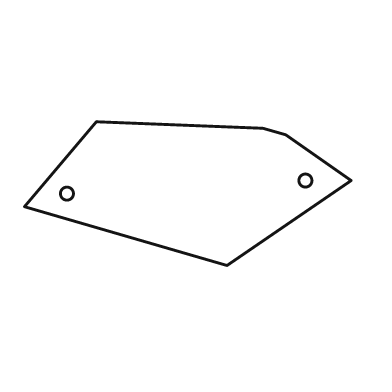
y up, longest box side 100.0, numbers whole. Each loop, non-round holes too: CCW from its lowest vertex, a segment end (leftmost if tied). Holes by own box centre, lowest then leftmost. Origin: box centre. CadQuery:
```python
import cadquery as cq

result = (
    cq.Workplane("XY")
    .moveTo(12.0, -22.0)
    .lineTo(50.0, 4.0)
    .lineTo(30.0, 18.0)
    .lineTo(23.0, 20.0)
    .lineTo(-28.0, 22.0)
    .lineTo(-50.0, -4.0)
    .close()
    .moveTo(-37.0, 0.0)
    .circle(2.0)
    .moveTo(36.0, 4.0)
    .circle(2.0)
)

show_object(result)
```